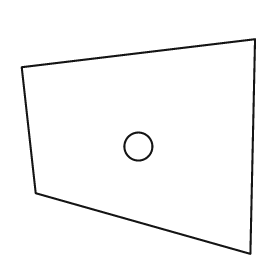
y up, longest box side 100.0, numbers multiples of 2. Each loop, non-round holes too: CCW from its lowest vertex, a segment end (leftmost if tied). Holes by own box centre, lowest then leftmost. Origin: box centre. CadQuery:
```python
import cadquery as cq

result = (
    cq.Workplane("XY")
    .moveTo(48.0, -46.0)
    .lineTo(50.0, 46.0)
    .lineTo(-50.0, 34.0)
    .lineTo(-44.0, -20.0)
    .close()
    .moveTo(0.0, 0.0)
    .circle(6.0)
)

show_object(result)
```